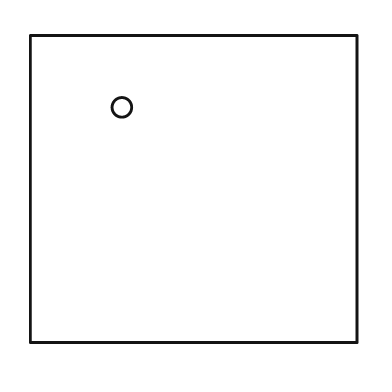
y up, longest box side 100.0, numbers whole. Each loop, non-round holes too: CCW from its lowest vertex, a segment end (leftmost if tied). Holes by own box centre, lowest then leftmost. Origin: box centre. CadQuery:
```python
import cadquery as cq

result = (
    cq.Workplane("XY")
    .moveTo(-50.0, -47.0)
    .lineTo(50.0, -47.0)
    .lineTo(50.0, 47.0)
    .lineTo(-50.0, 47.0)
    .close()
    .moveTo(-22.0, 25.0)
    .circle(3.0)
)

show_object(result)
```